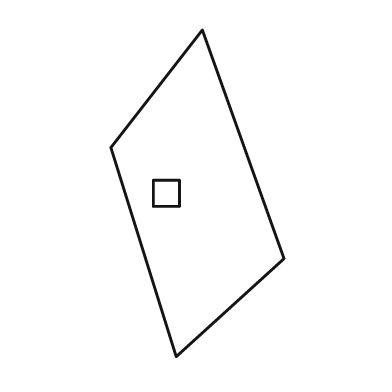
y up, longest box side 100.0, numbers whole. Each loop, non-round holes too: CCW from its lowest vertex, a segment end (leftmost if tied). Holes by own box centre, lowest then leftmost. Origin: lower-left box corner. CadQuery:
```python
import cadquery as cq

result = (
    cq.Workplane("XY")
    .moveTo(20.0, 0.0)
    .lineTo(53.0, 30.0)
    .lineTo(28.0, 100.0)
    .lineTo(0.0, 64.0)
    .close()
    .moveTo(13.0, 46.0)
    .lineTo(21.0, 46.0)
    .lineTo(21.0, 54.0)
    .lineTo(13.0, 54.0)
    .close()
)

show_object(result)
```